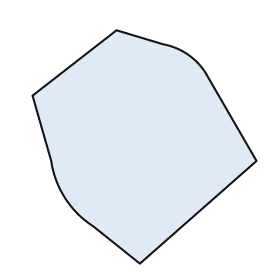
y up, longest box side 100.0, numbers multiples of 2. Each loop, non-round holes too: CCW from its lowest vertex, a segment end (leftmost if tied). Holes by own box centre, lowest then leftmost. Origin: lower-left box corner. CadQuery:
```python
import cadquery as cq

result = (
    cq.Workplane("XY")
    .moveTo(46.0, 0.0)
    .lineTo(96.0, 44.0)
    .lineTo(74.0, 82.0)
    .threePointArc((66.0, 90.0), (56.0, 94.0))
    .lineTo(36.0, 100.0)
    .lineTo(0.0, 72.0)
    .lineTo(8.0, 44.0)
    .threePointArc((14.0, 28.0), (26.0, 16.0))
    .close()
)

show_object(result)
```